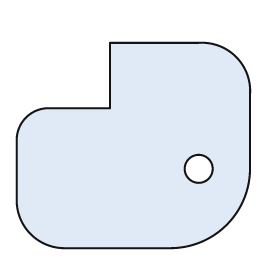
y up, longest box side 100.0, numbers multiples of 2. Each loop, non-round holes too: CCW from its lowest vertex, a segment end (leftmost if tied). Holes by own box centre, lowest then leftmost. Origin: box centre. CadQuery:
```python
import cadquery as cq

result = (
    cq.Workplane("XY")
    .moveTo(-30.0, -44.0)
    .lineTo(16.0, -44.0)
    .threePointArc((40.0, -34.0), (50.0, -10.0))
    .lineTo(50.0, 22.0)
    .threePointArc((44.0, 38.0), (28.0, 44.0))
    .lineTo(-10.0, 44.0)
    .lineTo(-10.0, 16.0)
    .lineTo(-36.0, 16.0)
    .threePointArc((-46.0, 12.0), (-50.0, 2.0))
    .lineTo(-50.0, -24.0)
    .threePointArc((-44.0, -38.0), (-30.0, -44.0))
    .close()
    .moveTo(28.0, -10.0)
    .circle(6.0)
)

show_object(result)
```